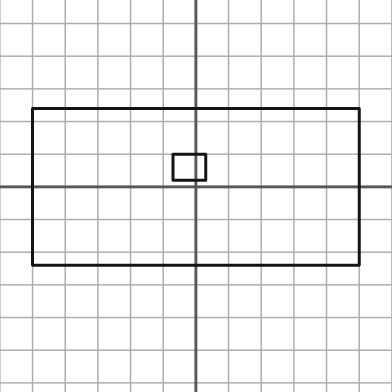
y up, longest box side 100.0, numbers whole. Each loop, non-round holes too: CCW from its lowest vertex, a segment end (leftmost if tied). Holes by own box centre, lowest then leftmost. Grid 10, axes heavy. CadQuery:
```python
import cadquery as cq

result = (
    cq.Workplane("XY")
    .moveTo(-50.0, -24.0)
    .lineTo(50.0, -24.0)
    .lineTo(50.0, 24.0)
    .lineTo(-50.0, 24.0)
    .close()
    .moveTo(-7.0, 2.0)
    .lineTo(3.0, 2.0)
    .lineTo(3.0, 10.0)
    .lineTo(-7.0, 10.0)
    .close()
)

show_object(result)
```